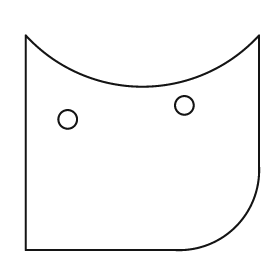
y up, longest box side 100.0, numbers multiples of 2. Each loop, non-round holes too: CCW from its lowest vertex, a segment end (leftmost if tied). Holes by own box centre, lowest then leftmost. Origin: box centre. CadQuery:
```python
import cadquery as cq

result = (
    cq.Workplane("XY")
    .moveTo(-50.0, -46.0)
    .lineTo(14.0, -46.0)
    .threePointArc((40.0, -36.0), (50.0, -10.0))
    .lineTo(50.0, 46.0)
    .threePointArc((0.0, 24.0), (-50.0, 46.0))
    .close()
    .moveTo(-32.0, 10.0)
    .circle(4.0)
    .moveTo(18.0, 16.0)
    .circle(4.0)
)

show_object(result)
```